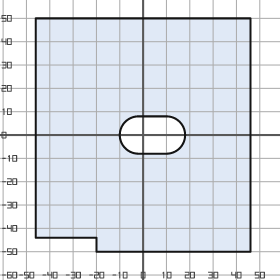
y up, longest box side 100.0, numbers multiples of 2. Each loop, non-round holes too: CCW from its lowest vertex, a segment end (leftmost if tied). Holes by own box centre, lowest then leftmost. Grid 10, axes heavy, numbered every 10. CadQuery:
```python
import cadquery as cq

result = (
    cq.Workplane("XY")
    .moveTo(-20.0, -50.0)
    .lineTo(46.0, -50.0)
    .lineTo(46.0, 50.0)
    .lineTo(-46.0, 50.0)
    .lineTo(-46.0, -44.0)
    .lineTo(-20.0, -44.0)
    .close()
    .moveTo(-2.0, -8.0)
    .lineTo(10.0, -8.0)
    .threePointArc((18.0, 0.0), (10.0, 8.0))
    .lineTo(-2.0, 8.0)
    .threePointArc((-10.0, 0.0), (-2.0, -8.0))
    .close()
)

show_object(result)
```